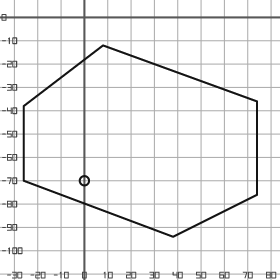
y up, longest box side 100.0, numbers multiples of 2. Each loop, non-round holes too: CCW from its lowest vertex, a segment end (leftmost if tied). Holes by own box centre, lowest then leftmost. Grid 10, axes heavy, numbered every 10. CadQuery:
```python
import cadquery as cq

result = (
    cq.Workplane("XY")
    .moveTo(38.0, -94.0)
    .lineTo(74.0, -76.0)
    .lineTo(74.0, -36.0)
    .lineTo(8.0, -12.0)
    .lineTo(-26.0, -38.0)
    .lineTo(-26.0, -70.0)
    .close()
    .moveTo(0.0, -70.0)
    .circle(2.0)
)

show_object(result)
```